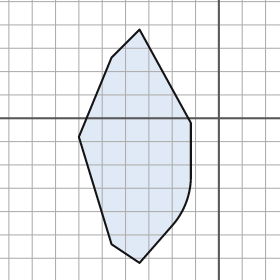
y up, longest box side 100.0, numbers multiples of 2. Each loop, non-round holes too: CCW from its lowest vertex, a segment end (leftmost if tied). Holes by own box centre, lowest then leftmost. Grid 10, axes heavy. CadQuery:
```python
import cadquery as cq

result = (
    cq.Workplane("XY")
    .moveTo(-34.0, -62.0)
    .lineTo(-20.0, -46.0)
    .threePointArc((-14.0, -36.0), (-12.0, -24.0))
    .lineTo(-12.0, -2.0)
    .lineTo(-34.0, 38.0)
    .lineTo(-46.0, 26.0)
    .lineTo(-60.0, -8.0)
    .lineTo(-46.0, -54.0)
    .close()
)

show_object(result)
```